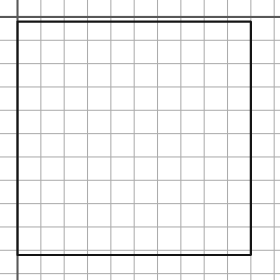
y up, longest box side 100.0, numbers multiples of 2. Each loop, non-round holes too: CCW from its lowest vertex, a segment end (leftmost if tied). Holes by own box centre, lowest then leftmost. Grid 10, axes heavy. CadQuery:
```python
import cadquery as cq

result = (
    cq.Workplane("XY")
    .moveTo(0.0, -102.0)
    .lineTo(100.0, -102.0)
    .lineTo(100.0, -2.0)
    .lineTo(0.0, -2.0)
    .close()
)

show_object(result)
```